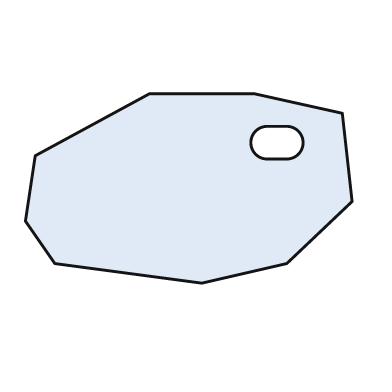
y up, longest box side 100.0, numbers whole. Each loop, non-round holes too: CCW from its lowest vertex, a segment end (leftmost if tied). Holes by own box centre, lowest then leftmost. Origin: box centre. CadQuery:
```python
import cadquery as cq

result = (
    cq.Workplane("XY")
    .moveTo(4.0, -29.0)
    .lineTo(30.0, -23.0)
    .lineTo(50.0, -4.0)
    .lineTo(47.0, 23.0)
    .lineTo(20.0, 29.0)
    .lineTo(-12.0, 29.0)
    .lineTo(-47.0, 10.0)
    .lineTo(-50.0, -10.0)
    .lineTo(-41.0, -23.0)
    .close()
    .moveTo(24.0, 9.0)
    .lineTo(30.0, 9.0)
    .threePointArc((35.0, 14.0), (30.0, 19.0))
    .lineTo(24.0, 19.0)
    .threePointArc((19.0, 14.0), (24.0, 9.0))
    .close()
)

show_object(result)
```